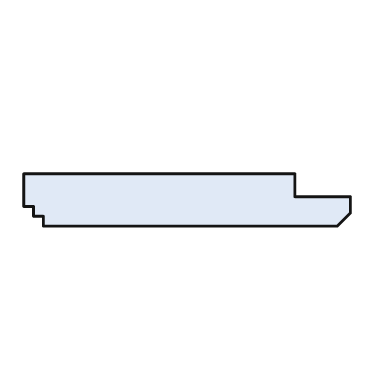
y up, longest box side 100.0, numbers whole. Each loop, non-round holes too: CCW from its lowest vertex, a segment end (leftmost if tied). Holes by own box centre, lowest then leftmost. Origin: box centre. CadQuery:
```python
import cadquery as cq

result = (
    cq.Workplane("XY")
    .moveTo(-44.0, -8.0)
    .lineTo(46.0, -8.0)
    .lineTo(50.0, -4.0)
    .lineTo(50.0, 1.0)
    .lineTo(33.0, 1.0)
    .lineTo(33.0, 8.0)
    .lineTo(-50.0, 8.0)
    .lineTo(-50.0, -2.0)
    .lineTo(-47.0, -2.0)
    .lineTo(-47.0, -5.0)
    .lineTo(-44.0, -5.0)
    .close()
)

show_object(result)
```